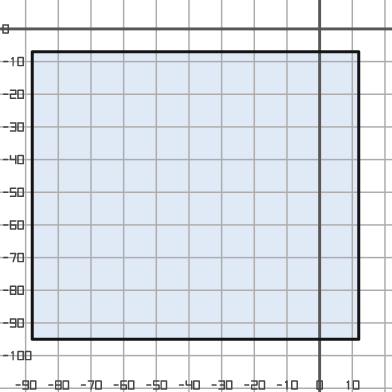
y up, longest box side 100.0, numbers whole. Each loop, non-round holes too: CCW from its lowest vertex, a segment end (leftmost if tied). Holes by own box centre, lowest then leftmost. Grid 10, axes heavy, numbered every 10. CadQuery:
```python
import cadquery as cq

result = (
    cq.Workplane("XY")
    .moveTo(-88.0, -95.0)
    .lineTo(12.0, -95.0)
    .lineTo(12.0, -7.0)
    .lineTo(-88.0, -7.0)
    .close()
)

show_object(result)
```